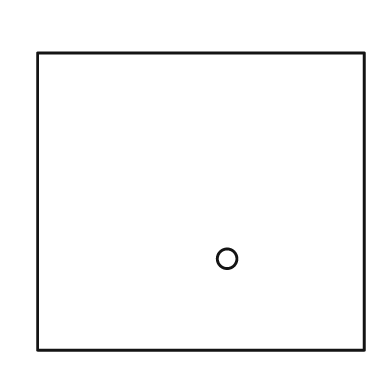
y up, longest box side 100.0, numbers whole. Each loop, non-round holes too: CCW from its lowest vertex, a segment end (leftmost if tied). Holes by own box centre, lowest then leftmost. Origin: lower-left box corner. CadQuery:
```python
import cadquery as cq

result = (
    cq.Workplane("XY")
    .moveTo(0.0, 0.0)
    .lineTo(100.0, 0.0)
    .lineTo(100.0, 91.0)
    .lineTo(0.0, 91.0)
    .close()
    .moveTo(58.0, 28.0)
    .circle(3.0)
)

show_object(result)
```